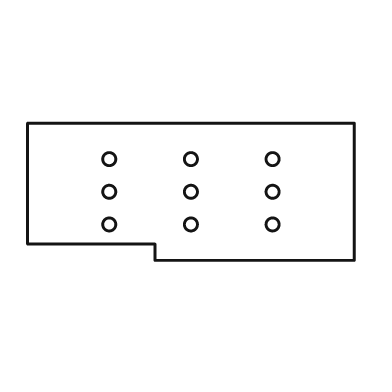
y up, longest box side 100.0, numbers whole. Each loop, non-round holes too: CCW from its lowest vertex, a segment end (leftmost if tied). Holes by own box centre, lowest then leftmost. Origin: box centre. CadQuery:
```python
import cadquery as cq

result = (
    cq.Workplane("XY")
    .moveTo(-11.0, -21.0)
    .lineTo(50.0, -21.0)
    .lineTo(50.0, 21.0)
    .lineTo(-50.0, 21.0)
    .lineTo(-50.0, -16.0)
    .lineTo(-11.0, -16.0)
    .close()
    .moveTo(-25.0, -10.0)
    .circle(2.0)
    .moveTo(0.0, -10.0)
    .circle(2.0)
    .moveTo(25.0, -10.0)
    .circle(2.0)
    .moveTo(-25.0, 0.0)
    .circle(2.0)
    .moveTo(0.0, 0.0)
    .circle(2.0)
    .moveTo(25.0, 0.0)
    .circle(2.0)
    .moveTo(-25.0, 10.0)
    .circle(2.0)
    .moveTo(0.0, 10.0)
    .circle(2.0)
    .moveTo(25.0, 10.0)
    .circle(2.0)
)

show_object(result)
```